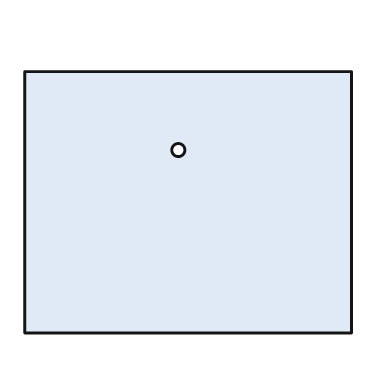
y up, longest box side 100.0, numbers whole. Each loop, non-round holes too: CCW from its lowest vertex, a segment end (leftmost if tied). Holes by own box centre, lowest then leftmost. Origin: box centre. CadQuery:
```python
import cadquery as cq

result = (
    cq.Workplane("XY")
    .moveTo(-50.0, -40.0)
    .lineTo(50.0, -40.0)
    .lineTo(50.0, 40.0)
    .lineTo(-50.0, 40.0)
    .close()
    .moveTo(-3.0, 16.0)
    .circle(2.0)
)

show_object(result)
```